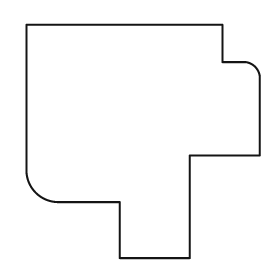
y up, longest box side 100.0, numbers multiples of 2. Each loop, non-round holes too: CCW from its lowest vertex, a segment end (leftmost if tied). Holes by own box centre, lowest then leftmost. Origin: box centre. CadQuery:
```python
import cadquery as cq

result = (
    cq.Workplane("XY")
    .moveTo(-10.0, -50.0)
    .lineTo(20.0, -50.0)
    .lineTo(20.0, -6.0)
    .lineTo(50.0, -6.0)
    .lineTo(50.0, 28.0)
    .threePointArc((48.0, 32.0), (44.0, 34.0))
    .lineTo(34.0, 34.0)
    .lineTo(34.0, 50.0)
    .lineTo(-50.0, 50.0)
    .lineTo(-50.0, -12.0)
    .threePointArc((-46.0, -22.0), (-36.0, -26.0))
    .lineTo(-10.0, -26.0)
    .close()
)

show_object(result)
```